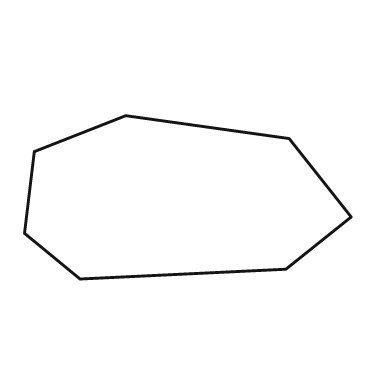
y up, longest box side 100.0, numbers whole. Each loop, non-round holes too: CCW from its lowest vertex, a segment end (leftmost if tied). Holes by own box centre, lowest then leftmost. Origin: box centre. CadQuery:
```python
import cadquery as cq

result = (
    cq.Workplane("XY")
    .moveTo(-33.0, -25.0)
    .lineTo(30.0, -22.0)
    .lineTo(50.0, -6.0)
    .lineTo(31.0, 18.0)
    .lineTo(-19.0, 25.0)
    .lineTo(-47.0, 14.0)
    .lineTo(-50.0, -11.0)
    .close()
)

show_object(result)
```